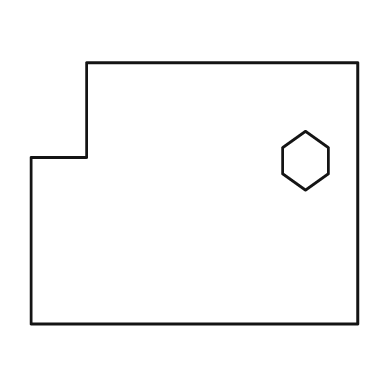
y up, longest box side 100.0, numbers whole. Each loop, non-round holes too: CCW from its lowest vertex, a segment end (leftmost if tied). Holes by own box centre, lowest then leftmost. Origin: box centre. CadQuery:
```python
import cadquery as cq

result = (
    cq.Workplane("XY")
    .moveTo(-50.0, -40.0)
    .lineTo(50.0, -40.0)
    .lineTo(50.0, 40.0)
    .lineTo(-33.0, 40.0)
    .lineTo(-33.0, 11.0)
    .lineTo(-50.0, 11.0)
    .close()
    .moveTo(34.0, 1.0)
    .lineTo(41.0, 6.0)
    .lineTo(41.0, 14.0)
    .lineTo(34.0, 19.0)
    .lineTo(27.0, 14.0)
    .lineTo(27.0, 6.0)
    .close()
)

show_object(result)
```